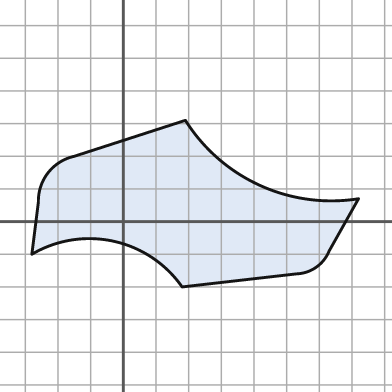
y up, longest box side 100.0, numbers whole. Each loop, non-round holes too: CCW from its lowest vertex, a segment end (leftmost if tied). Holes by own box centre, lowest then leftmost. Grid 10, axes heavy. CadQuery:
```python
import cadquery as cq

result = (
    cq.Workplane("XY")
    .moveTo(18.0, -20.0)
    .lineTo(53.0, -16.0)
    .threePointArc((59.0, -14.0), (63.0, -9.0))
    .lineTo(72.0, 7.0)
    .threePointArc((42.0, 11.0), (19.0, 31.0))
    .lineTo(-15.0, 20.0)
    .threePointArc((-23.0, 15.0), (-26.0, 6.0))
    .lineTo(-28.0, -10.0)
    .threePointArc((-3.0, -6.0), (18.0, -20.0))
    .close()
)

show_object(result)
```